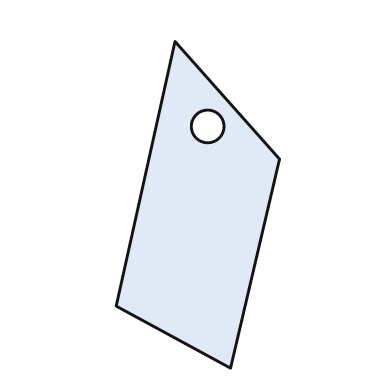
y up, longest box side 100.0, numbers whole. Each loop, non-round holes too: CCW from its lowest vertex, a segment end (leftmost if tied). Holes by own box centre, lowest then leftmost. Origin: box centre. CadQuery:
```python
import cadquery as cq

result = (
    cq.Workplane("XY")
    .moveTo(10.0, -50.0)
    .lineTo(25.0, 14.0)
    .lineTo(-7.0, 50.0)
    .lineTo(-25.0, -31.0)
    .close()
    .moveTo(3.0, 24.0)
    .circle(5.0)
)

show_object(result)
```